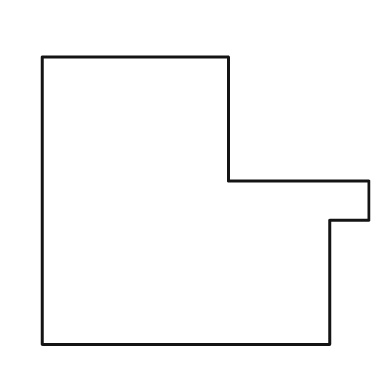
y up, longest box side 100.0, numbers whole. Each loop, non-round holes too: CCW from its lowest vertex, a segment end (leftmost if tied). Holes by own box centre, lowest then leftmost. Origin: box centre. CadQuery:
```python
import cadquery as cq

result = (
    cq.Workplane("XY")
    .moveTo(-50.0, -44.0)
    .lineTo(38.0, -44.0)
    .lineTo(38.0, -6.0)
    .lineTo(50.0, -6.0)
    .lineTo(50.0, 6.0)
    .lineTo(7.0, 6.0)
    .lineTo(7.0, 44.0)
    .lineTo(-50.0, 44.0)
    .close()
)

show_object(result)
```